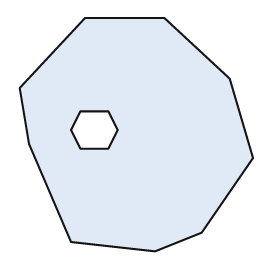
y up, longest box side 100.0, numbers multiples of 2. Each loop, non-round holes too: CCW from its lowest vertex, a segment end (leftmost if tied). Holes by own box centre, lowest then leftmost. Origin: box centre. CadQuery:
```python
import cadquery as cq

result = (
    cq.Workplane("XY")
    .moveTo(8.0, -50.0)
    .lineTo(28.0, -42.0)
    .lineTo(50.0, -10.0)
    .lineTo(40.0, 24.0)
    .lineTo(12.0, 50.0)
    .lineTo(-22.0, 50.0)
    .lineTo(-50.0, 20.0)
    .lineTo(-46.0, -4.0)
    .lineTo(-28.0, -46.0)
    .close()
    .moveTo(-24.0, -6.0)
    .lineTo(-12.0, -6.0)
    .lineTo(-8.0, 2.0)
    .lineTo(-12.0, 10.0)
    .lineTo(-24.0, 10.0)
    .lineTo(-28.0, 2.0)
    .close()
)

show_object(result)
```